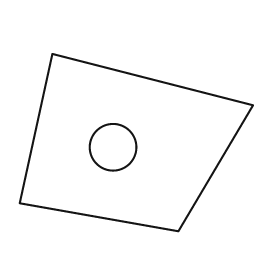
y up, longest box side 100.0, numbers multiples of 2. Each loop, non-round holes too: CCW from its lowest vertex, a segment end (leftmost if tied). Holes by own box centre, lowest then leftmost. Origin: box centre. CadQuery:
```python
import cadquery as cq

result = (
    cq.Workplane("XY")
    .moveTo(18.0, -38.0)
    .lineTo(50.0, 16.0)
    .lineTo(-36.0, 38.0)
    .lineTo(-50.0, -26.0)
    .close()
    .moveTo(-10.0, -2.0)
    .circle(10.0)
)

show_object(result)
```